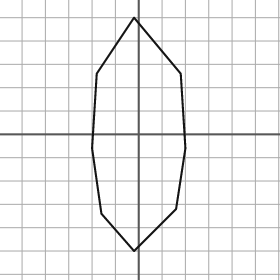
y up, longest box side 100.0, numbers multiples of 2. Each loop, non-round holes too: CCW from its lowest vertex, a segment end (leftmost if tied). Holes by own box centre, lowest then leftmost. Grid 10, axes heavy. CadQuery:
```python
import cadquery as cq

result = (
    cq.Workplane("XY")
    .moveTo(-2.0, -50.0)
    .lineTo(16.0, -32.0)
    .lineTo(20.0, -6.0)
    .lineTo(18.0, 26.0)
    .lineTo(-2.0, 50.0)
    .lineTo(-18.0, 26.0)
    .lineTo(-20.0, -6.0)
    .lineTo(-16.0, -34.0)
    .close()
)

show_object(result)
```